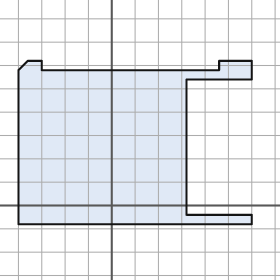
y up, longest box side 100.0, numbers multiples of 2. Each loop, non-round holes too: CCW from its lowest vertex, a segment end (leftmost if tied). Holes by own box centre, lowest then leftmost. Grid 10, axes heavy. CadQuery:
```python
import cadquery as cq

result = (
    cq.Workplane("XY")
    .moveTo(-40.0, -8.0)
    .lineTo(60.0, -8.0)
    .lineTo(60.0, -4.0)
    .lineTo(32.0, -4.0)
    .lineTo(32.0, 54.0)
    .lineTo(60.0, 54.0)
    .lineTo(60.0, 62.0)
    .lineTo(46.0, 62.0)
    .lineTo(46.0, 58.0)
    .lineTo(-30.0, 58.0)
    .lineTo(-30.0, 62.0)
    .lineTo(-36.0, 62.0)
    .lineTo(-40.0, 58.0)
    .close()
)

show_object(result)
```